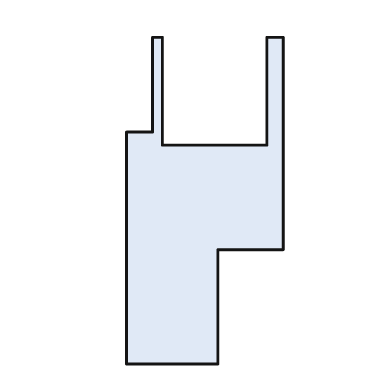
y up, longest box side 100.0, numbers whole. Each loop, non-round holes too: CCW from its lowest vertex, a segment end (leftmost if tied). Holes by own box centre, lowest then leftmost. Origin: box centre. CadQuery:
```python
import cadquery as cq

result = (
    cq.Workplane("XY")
    .moveTo(-24.0, -50.0)
    .lineTo(4.0, -50.0)
    .lineTo(4.0, -15.0)
    .lineTo(24.0, -15.0)
    .lineTo(24.0, 50.0)
    .lineTo(19.0, 50.0)
    .lineTo(19.0, 17.0)
    .lineTo(-13.0, 17.0)
    .lineTo(-13.0, 50.0)
    .lineTo(-16.0, 50.0)
    .lineTo(-16.0, 21.0)
    .lineTo(-24.0, 21.0)
    .close()
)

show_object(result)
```